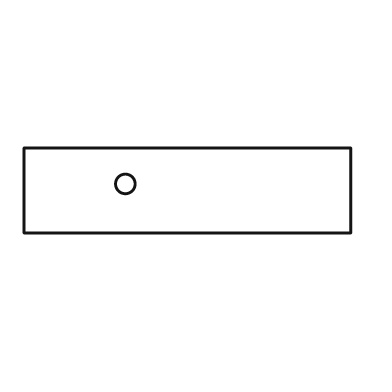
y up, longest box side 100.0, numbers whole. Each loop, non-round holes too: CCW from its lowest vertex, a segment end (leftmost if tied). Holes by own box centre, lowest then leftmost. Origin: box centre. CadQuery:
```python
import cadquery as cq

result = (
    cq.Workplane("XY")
    .moveTo(-50.0, -13.0)
    .lineTo(50.0, -13.0)
    .lineTo(50.0, 13.0)
    .lineTo(-50.0, 13.0)
    .close()
    .moveTo(-19.0, 2.0)
    .circle(3.0)
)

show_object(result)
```